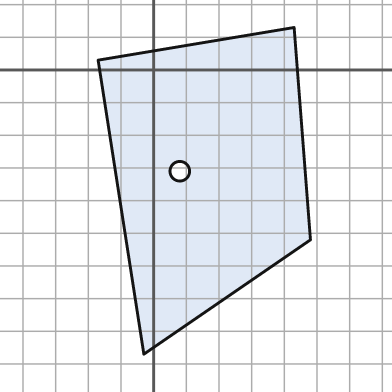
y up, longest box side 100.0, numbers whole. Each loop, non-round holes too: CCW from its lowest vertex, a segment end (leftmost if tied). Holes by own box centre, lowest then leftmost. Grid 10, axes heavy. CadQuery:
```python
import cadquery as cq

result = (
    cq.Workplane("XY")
    .moveTo(-3.0, -87.0)
    .lineTo(48.0, -52.0)
    .lineTo(43.0, 13.0)
    .lineTo(-17.0, 3.0)
    .close()
    .moveTo(8.0, -31.0)
    .circle(3.0)
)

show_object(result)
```